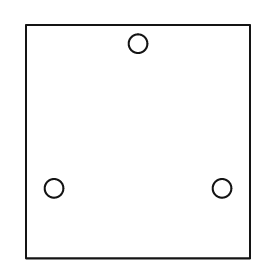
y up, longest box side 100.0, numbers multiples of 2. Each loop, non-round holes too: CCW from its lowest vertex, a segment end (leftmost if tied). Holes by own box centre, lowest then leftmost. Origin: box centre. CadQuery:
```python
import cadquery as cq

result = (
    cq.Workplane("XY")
    .moveTo(-48.0, -50.0)
    .lineTo(48.0, -50.0)
    .lineTo(48.0, 50.0)
    .lineTo(-48.0, 50.0)
    .close()
    .moveTo(-36.0, -20.0)
    .circle(4.0)
    .moveTo(36.0, -20.0)
    .circle(4.0)
    .moveTo(0.0, 42.0)
    .circle(4.0)
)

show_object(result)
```